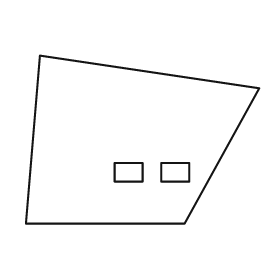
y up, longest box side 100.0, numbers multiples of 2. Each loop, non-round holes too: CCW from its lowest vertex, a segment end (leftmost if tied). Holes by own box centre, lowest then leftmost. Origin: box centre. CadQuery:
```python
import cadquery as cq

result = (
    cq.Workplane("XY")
    .moveTo(-50.0, -36.0)
    .lineTo(18.0, -36.0)
    .lineTo(50.0, 22.0)
    .lineTo(-44.0, 36.0)
    .close()
    .moveTo(-12.0, -18.0)
    .lineTo(0.0, -18.0)
    .lineTo(0.0, -10.0)
    .lineTo(-12.0, -10.0)
    .close()
    .moveTo(8.0, -18.0)
    .lineTo(20.0, -18.0)
    .lineTo(20.0, -10.0)
    .lineTo(8.0, -10.0)
    .close()
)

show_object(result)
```